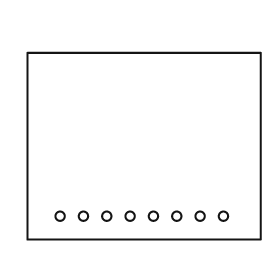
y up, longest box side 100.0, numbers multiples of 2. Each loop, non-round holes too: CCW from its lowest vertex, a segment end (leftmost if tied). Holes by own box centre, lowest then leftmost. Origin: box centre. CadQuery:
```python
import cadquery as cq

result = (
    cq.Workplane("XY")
    .moveTo(-50.0, -40.0)
    .lineTo(50.0, -40.0)
    .lineTo(50.0, 40.0)
    .lineTo(-50.0, 40.0)
    .close()
    .moveTo(-36.0, -30.0)
    .circle(2.0)
    .moveTo(-26.0, -30.0)
    .circle(2.0)
    .moveTo(-16.0, -30.0)
    .circle(2.0)
    .moveTo(-6.0, -30.0)
    .circle(2.0)
    .moveTo(4.0, -30.0)
    .circle(2.0)
    .moveTo(14.0, -30.0)
    .circle(2.0)
    .moveTo(24.0, -30.0)
    .circle(2.0)
    .moveTo(34.0, -30.0)
    .circle(2.0)
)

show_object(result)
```